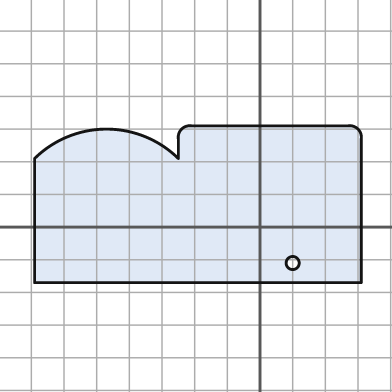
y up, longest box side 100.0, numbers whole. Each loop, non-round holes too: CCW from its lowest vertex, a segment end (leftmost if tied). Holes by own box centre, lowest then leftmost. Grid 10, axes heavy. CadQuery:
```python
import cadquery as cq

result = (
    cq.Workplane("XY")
    .moveTo(-69.0, -17.0)
    .lineTo(31.0, -17.0)
    .lineTo(31.0, 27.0)
    .threePointArc((30.0, 30.0), (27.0, 31.0))
    .lineTo(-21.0, 31.0)
    .threePointArc((-24.0, 30.0), (-25.0, 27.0))
    .lineTo(-25.0, 21.0)
    .threePointArc((-47.0, 30.0), (-69.0, 21.0))
    .close()
    .moveTo(10.0, -11.0)
    .circle(2.0)
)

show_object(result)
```